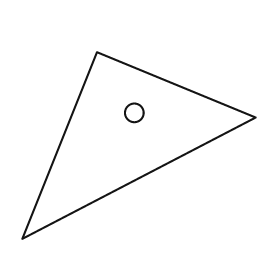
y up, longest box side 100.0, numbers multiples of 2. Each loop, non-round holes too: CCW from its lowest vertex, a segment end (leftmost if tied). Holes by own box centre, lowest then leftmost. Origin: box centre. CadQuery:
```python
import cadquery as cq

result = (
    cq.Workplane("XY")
    .moveTo(-50.0, -40.0)
    .lineTo(50.0, 12.0)
    .lineTo(-18.0, 40.0)
    .close()
    .moveTo(-2.0, 14.0)
    .circle(4.0)
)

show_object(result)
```